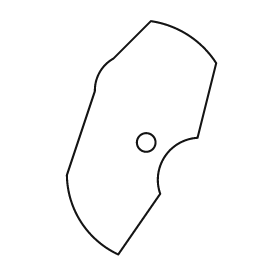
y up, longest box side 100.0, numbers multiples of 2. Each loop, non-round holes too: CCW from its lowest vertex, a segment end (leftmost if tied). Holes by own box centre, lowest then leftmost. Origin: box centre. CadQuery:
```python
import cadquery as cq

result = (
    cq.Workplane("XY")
    .moveTo(-10.0, -50.0)
    .lineTo(8.0, -24.0)
    .threePointArc((10.0, -8.0), (24.0, 0.0))
    .lineTo(32.0, 32.0)
    .threePointArc((20.0, 44.0), (4.0, 50.0))
    .lineTo(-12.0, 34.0)
    .threePointArc((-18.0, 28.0), (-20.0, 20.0))
    .lineTo(-32.0, -16.0)
    .threePointArc((-26.0, -36.0), (-10.0, -50.0))
    .close()
    .moveTo(2.0, -2.0)
    .circle(4.0)
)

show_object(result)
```